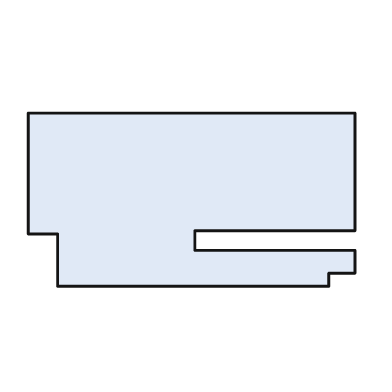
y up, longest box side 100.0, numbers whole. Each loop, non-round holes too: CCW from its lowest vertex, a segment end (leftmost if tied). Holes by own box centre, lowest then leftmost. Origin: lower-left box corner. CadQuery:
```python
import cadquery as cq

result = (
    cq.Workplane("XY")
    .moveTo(9.0, 0.0)
    .lineTo(92.0, 0.0)
    .lineTo(92.0, 4.0)
    .lineTo(100.0, 4.0)
    .lineTo(100.0, 11.0)
    .lineTo(51.0, 11.0)
    .lineTo(51.0, 17.0)
    .lineTo(100.0, 17.0)
    .lineTo(100.0, 53.0)
    .lineTo(0.0, 53.0)
    .lineTo(0.0, 16.0)
    .lineTo(9.0, 16.0)
    .close()
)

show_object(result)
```